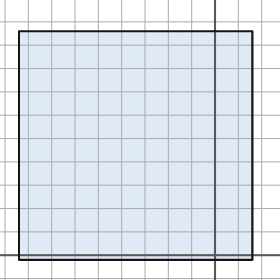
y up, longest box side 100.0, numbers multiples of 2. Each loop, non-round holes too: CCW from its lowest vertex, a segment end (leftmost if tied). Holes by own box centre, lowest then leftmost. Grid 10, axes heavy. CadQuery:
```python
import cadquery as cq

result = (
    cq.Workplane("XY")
    .moveTo(-84.0, -2.0)
    .lineTo(16.0, -2.0)
    .lineTo(16.0, 96.0)
    .lineTo(-84.0, 96.0)
    .close()
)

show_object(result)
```